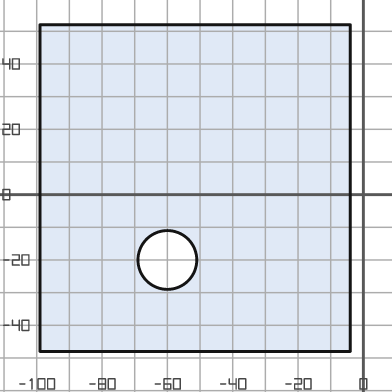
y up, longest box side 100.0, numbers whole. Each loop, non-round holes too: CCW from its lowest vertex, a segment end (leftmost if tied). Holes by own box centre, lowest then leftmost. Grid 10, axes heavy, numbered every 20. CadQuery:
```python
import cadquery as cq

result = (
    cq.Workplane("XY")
    .moveTo(-99.0, -48.0)
    .lineTo(-4.0, -48.0)
    .lineTo(-4.0, 52.0)
    .lineTo(-99.0, 52.0)
    .close()
    .moveTo(-60.0, -20.0)
    .circle(9.0)
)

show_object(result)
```